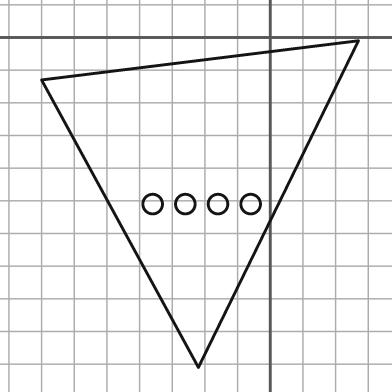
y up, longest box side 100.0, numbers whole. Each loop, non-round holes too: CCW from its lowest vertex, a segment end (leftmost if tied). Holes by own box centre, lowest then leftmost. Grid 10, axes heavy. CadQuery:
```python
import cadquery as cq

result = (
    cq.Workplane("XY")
    .moveTo(-22.0, -101.0)
    .lineTo(27.0, -1.0)
    .lineTo(-70.0, -13.0)
    .close()
    .moveTo(-36.0, -51.0)
    .circle(3.0)
    .moveTo(-26.0, -51.0)
    .circle(3.0)
    .moveTo(-16.0, -51.0)
    .circle(3.0)
    .moveTo(-6.0, -51.0)
    .circle(3.0)
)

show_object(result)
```